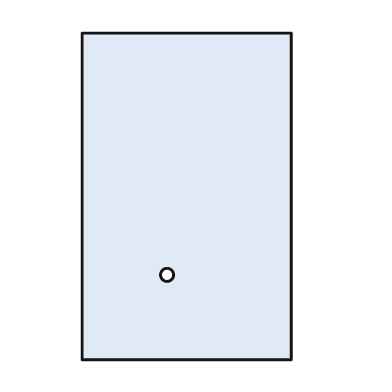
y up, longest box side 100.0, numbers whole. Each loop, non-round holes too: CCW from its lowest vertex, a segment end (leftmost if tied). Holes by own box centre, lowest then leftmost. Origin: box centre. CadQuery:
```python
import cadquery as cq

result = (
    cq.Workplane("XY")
    .moveTo(-32.0, -50.0)
    .lineTo(32.0, -50.0)
    .lineTo(32.0, 50.0)
    .lineTo(-32.0, 50.0)
    .close()
    .moveTo(-6.0, -24.0)
    .circle(2.0)
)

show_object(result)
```